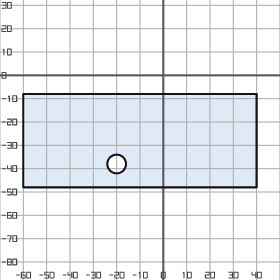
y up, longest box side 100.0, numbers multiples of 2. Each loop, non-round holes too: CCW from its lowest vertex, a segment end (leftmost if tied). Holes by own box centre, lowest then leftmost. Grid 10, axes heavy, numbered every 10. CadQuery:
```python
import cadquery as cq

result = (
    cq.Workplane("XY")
    .moveTo(-60.0, -48.0)
    .lineTo(40.0, -48.0)
    .lineTo(40.0, -8.0)
    .lineTo(-60.0, -8.0)
    .close()
    .moveTo(-20.0, -38.0)
    .circle(4.0)
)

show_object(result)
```